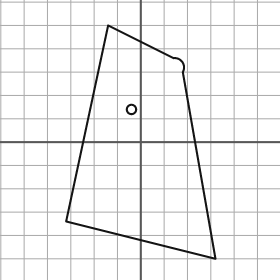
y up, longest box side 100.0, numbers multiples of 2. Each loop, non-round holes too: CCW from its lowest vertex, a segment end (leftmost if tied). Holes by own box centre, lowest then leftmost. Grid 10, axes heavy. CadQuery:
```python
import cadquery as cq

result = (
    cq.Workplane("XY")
    .moveTo(32.0, -50.0)
    .lineTo(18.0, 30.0)
    .threePointArc((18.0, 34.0), (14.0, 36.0))
    .lineTo(-14.0, 50.0)
    .lineTo(-32.0, -34.0)
    .close()
    .moveTo(-4.0, 14.0)
    .circle(2.0)
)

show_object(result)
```